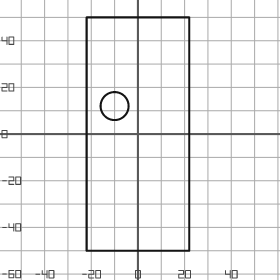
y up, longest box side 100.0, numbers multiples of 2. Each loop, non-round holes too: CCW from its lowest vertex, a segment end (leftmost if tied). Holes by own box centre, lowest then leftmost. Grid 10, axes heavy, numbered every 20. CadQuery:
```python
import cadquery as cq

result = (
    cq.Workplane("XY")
    .moveTo(-22.0, -50.0)
    .lineTo(22.0, -50.0)
    .lineTo(22.0, 50.0)
    .lineTo(-22.0, 50.0)
    .close()
    .moveTo(-10.0, 12.0)
    .circle(6.0)
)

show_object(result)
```